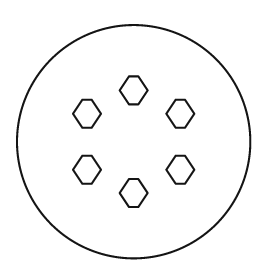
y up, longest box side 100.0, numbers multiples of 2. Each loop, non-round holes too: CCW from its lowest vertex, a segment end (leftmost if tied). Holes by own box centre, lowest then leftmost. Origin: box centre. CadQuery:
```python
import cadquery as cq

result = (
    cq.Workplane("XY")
    .moveTo(0.0, 0.0)
    .circle(50.0)
    .moveTo(-2.0, -28.0)
    .lineTo(2.0, -28.0)
    .lineTo(6.0, -22.0)
    .lineTo(2.0, -16.0)
    .lineTo(-2.0, -16.0)
    .lineTo(-6.0, -22.0)
    .close()
    .moveTo(-22.0, -18.0)
    .lineTo(-18.0, -18.0)
    .lineTo(-14.0, -12.0)
    .lineTo(-18.0, -6.0)
    .lineTo(-22.0, -6.0)
    .lineTo(-26.0, -12.0)
    .close()
    .moveTo(18.0, -18.0)
    .lineTo(22.0, -18.0)
    .lineTo(26.0, -12.0)
    .lineTo(22.0, -6.0)
    .lineTo(18.0, -6.0)
    .lineTo(14.0, -12.0)
    .close()
    .moveTo(-22.0, 6.0)
    .lineTo(-18.0, 6.0)
    .lineTo(-14.0, 12.0)
    .lineTo(-18.0, 18.0)
    .lineTo(-22.0, 18.0)
    .lineTo(-26.0, 12.0)
    .close()
    .moveTo(18.0, 6.0)
    .lineTo(22.0, 6.0)
    .lineTo(26.0, 12.0)
    .lineTo(22.0, 18.0)
    .lineTo(18.0, 18.0)
    .lineTo(14.0, 12.0)
    .close()
    .moveTo(-2.0, 16.0)
    .lineTo(2.0, 16.0)
    .lineTo(6.0, 22.0)
    .lineTo(2.0, 28.0)
    .lineTo(-2.0, 28.0)
    .lineTo(-6.0, 22.0)
    .close()
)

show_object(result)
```